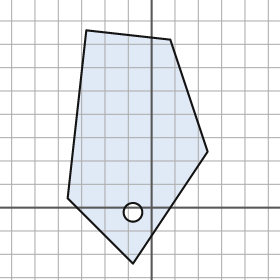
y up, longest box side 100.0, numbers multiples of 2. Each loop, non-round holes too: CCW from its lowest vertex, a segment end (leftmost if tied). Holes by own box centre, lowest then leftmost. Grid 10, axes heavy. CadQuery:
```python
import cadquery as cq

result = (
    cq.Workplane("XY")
    .moveTo(-8.0, -24.0)
    .lineTo(24.0, 24.0)
    .lineTo(8.0, 72.0)
    .lineTo(-28.0, 76.0)
    .lineTo(-36.0, 4.0)
    .close()
    .moveTo(-8.0, -2.0)
    .circle(4.0)
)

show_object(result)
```